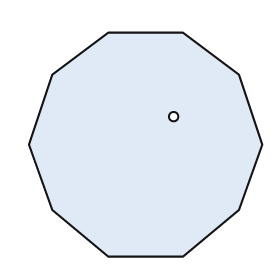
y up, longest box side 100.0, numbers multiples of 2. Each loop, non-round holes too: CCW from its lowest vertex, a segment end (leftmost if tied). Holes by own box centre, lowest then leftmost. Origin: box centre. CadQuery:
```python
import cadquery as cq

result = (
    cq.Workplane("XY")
    .moveTo(-16.0, -48.0)
    .lineTo(16.0, -48.0)
    .lineTo(40.0, -28.0)
    .lineTo(50.0, 0.0)
    .lineTo(40.0, 30.0)
    .lineTo(16.0, 48.0)
    .lineTo(-16.0, 48.0)
    .lineTo(-40.0, 30.0)
    .lineTo(-50.0, 0.0)
    .lineTo(-40.0, -28.0)
    .close()
    .moveTo(12.0, 12.0)
    .circle(2.0)
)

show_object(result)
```